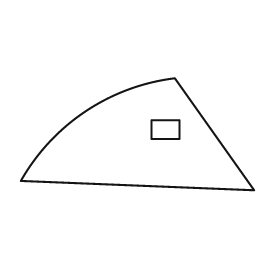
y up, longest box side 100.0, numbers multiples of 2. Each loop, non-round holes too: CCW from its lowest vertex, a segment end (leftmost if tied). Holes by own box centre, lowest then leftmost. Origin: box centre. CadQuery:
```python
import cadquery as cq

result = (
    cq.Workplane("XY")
    .moveTo(50.0, -24.0)
    .lineTo(16.0, 24.0)
    .threePointArc((-22.0, 10.0), (-50.0, -20.0))
    .close()
    .moveTo(6.0, -2.0)
    .lineTo(18.0, -2.0)
    .lineTo(18.0, 6.0)
    .lineTo(6.0, 6.0)
    .close()
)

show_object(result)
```